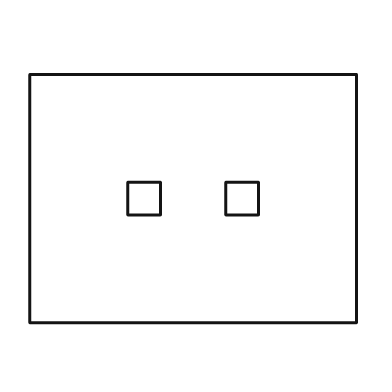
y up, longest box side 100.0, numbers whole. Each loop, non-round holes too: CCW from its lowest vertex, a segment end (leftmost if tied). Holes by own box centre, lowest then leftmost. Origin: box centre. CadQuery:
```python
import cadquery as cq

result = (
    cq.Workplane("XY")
    .moveTo(-50.0, -38.0)
    .lineTo(50.0, -38.0)
    .lineTo(50.0, 38.0)
    .lineTo(-50.0, 38.0)
    .close()
    .moveTo(-20.0, -5.0)
    .lineTo(-10.0, -5.0)
    .lineTo(-10.0, 5.0)
    .lineTo(-20.0, 5.0)
    .close()
    .moveTo(10.0, -5.0)
    .lineTo(20.0, -5.0)
    .lineTo(20.0, 5.0)
    .lineTo(10.0, 5.0)
    .close()
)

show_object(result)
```